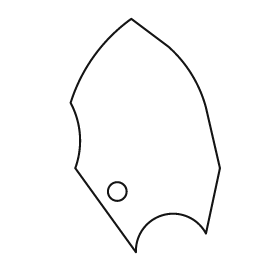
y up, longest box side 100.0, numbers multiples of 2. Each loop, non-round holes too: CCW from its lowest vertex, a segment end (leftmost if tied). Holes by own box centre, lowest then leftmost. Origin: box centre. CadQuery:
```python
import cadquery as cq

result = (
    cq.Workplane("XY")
    .moveTo(-4.0, -50.0)
    .threePointArc((8.0, -34.0), (26.0, -42.0))
    .lineTo(32.0, -14.0)
    .lineTo(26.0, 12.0)
    .threePointArc((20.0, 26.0), (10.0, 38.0))
    .lineTo(-6.0, 50.0)
    .threePointArc((-22.0, 34.0), (-32.0, 14.0))
    .threePointArc((-28.0, 0.0), (-30.0, -14.0))
    .close()
    .moveTo(-12.0, -24.0)
    .circle(4.0)
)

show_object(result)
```